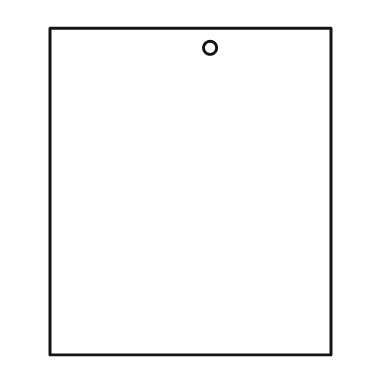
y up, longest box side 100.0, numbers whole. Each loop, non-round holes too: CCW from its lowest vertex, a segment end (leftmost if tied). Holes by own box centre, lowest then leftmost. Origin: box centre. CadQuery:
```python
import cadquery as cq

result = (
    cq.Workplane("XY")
    .moveTo(-43.0, -50.0)
    .lineTo(43.0, -50.0)
    .lineTo(43.0, 50.0)
    .lineTo(-43.0, 50.0)
    .close()
    .moveTo(6.0, 44.0)
    .circle(2.0)
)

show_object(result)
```